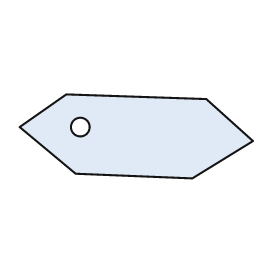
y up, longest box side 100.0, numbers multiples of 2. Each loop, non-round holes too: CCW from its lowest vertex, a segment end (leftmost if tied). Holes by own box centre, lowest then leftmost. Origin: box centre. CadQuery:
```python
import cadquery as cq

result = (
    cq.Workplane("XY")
    .moveTo(24.0, -18.0)
    .lineTo(50.0, -2.0)
    .lineTo(30.0, 16.0)
    .lineTo(-30.0, 18.0)
    .lineTo(-50.0, 4.0)
    .lineTo(-26.0, -16.0)
    .close()
    .moveTo(-24.0, 4.0)
    .circle(4.0)
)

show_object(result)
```